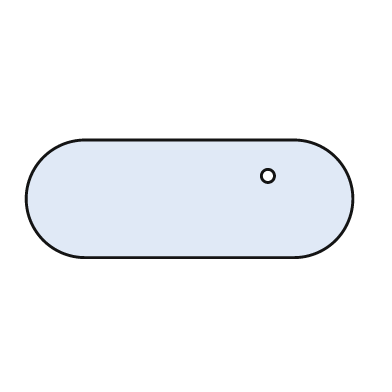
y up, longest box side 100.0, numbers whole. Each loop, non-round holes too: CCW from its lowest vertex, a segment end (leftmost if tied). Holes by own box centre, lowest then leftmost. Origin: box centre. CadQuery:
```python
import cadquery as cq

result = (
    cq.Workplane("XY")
    .moveTo(-32.0, -18.0)
    .lineTo(32.0, -18.0)
    .threePointArc((50.0, 0.0), (32.0, 18.0))
    .lineTo(-32.0, 18.0)
    .threePointArc((-50.0, 0.0), (-32.0, -18.0))
    .close()
    .moveTo(24.0, 7.0)
    .circle(2.0)
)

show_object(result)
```